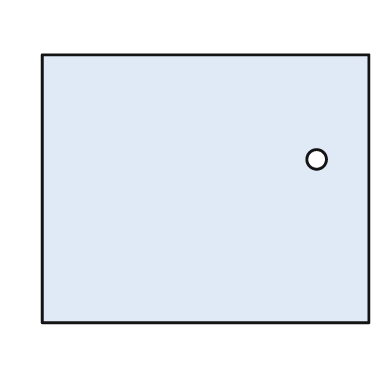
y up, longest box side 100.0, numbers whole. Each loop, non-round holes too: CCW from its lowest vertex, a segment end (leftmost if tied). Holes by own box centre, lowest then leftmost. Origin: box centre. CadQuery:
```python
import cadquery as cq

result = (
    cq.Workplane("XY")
    .moveTo(-50.0, -41.0)
    .lineTo(50.0, -41.0)
    .lineTo(50.0, 41.0)
    .lineTo(-50.0, 41.0)
    .close()
    .moveTo(34.0, 9.0)
    .circle(3.0)
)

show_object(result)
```